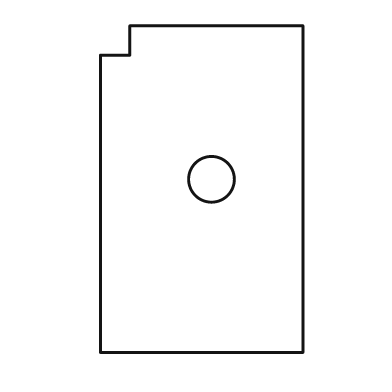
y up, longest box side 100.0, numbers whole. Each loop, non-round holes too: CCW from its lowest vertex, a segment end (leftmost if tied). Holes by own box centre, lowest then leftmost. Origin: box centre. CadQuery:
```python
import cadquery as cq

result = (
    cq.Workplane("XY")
    .moveTo(-31.0, -50.0)
    .lineTo(31.0, -50.0)
    .lineTo(31.0, 50.0)
    .lineTo(-22.0, 50.0)
    .lineTo(-22.0, 41.0)
    .lineTo(-31.0, 41.0)
    .close()
    .moveTo(3.0, 3.0)
    .circle(7.0)
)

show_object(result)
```